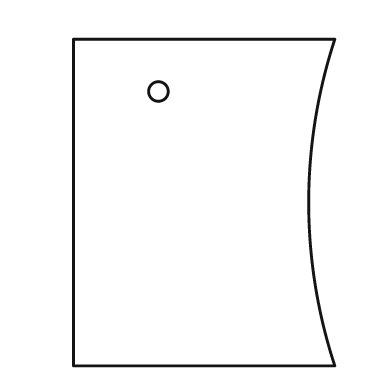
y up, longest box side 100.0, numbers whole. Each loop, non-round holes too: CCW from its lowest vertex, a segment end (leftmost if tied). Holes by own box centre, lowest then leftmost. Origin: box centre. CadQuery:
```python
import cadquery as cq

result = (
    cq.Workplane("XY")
    .moveTo(-40.0, -50.0)
    .lineTo(40.0, -50.0)
    .threePointArc((32.0, 0.0), (40.0, 50.0))
    .lineTo(-40.0, 50.0)
    .close()
    .moveTo(-14.0, 34.0)
    .circle(3.0)
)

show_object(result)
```